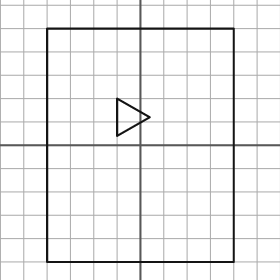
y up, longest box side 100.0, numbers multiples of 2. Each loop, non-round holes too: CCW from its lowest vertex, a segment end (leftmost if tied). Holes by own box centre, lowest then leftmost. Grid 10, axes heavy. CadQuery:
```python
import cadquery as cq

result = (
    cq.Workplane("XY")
    .moveTo(-40.0, -50.0)
    .lineTo(40.0, -50.0)
    .lineTo(40.0, 50.0)
    .lineTo(-40.0, 50.0)
    .close()
    .moveTo(-10.0, 4.0)
    .lineTo(4.0, 12.0)
    .lineTo(-10.0, 20.0)
    .close()
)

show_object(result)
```